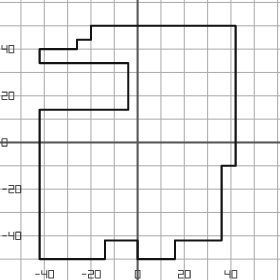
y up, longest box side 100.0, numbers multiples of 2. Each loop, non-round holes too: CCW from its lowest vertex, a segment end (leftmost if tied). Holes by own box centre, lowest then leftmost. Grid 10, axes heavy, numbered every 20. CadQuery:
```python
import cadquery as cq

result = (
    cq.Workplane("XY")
    .moveTo(-42.0, -50.0)
    .lineTo(-14.0, -50.0)
    .lineTo(-14.0, -42.0)
    .lineTo(0.0, -42.0)
    .lineTo(0.0, -50.0)
    .lineTo(16.0, -50.0)
    .lineTo(16.0, -42.0)
    .lineTo(36.0, -42.0)
    .lineTo(36.0, -10.0)
    .lineTo(42.0, -10.0)
    .lineTo(42.0, 50.0)
    .lineTo(-20.0, 50.0)
    .lineTo(-20.0, 44.0)
    .lineTo(-26.0, 44.0)
    .lineTo(-26.0, 40.0)
    .lineTo(-42.0, 40.0)
    .lineTo(-42.0, 34.0)
    .lineTo(-4.0, 34.0)
    .lineTo(-4.0, 14.0)
    .lineTo(-42.0, 14.0)
    .close()
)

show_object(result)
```